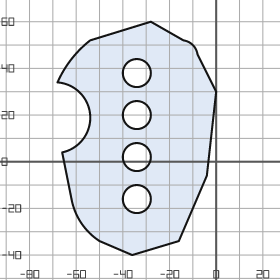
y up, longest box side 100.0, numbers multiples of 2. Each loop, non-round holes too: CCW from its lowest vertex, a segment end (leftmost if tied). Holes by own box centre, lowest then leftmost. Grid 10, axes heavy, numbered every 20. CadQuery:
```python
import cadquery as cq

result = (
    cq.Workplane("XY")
    .moveTo(-36.0, -40.0)
    .lineTo(-16.0, -34.0)
    .lineTo(-4.0, -6.0)
    .lineTo(0.0, 30.0)
    .lineTo(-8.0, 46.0)
    .threePointArc((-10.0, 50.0), (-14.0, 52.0))
    .lineTo(-28.0, 60.0)
    .lineTo(-54.0, 52.0)
    .threePointArc((-62.0, 44.0), (-68.0, 34.0))
    .threePointArc((-54.0, 20.0), (-66.0, 4.0))
    .lineTo(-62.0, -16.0)
    .threePointArc((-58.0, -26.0), (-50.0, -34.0))
    .close()
    .moveTo(-34.0, -16.0)
    .circle(6.0)
    .moveTo(-34.0, 2.0)
    .circle(6.0)
    .moveTo(-34.0, 20.0)
    .circle(6.0)
    .moveTo(-34.0, 38.0)
    .circle(6.0)
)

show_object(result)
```